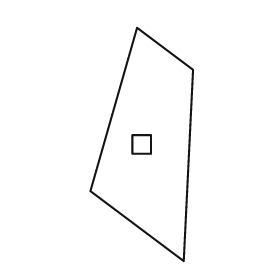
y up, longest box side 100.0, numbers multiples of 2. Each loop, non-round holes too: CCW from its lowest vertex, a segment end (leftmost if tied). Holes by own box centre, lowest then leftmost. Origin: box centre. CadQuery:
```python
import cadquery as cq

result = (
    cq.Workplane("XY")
    .moveTo(18.0, -50.0)
    .lineTo(22.0, 32.0)
    .lineTo(-2.0, 50.0)
    .lineTo(-22.0, -20.0)
    .close()
    .moveTo(-4.0, -4.0)
    .lineTo(4.0, -4.0)
    .lineTo(4.0, 4.0)
    .lineTo(-4.0, 4.0)
    .close()
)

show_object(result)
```